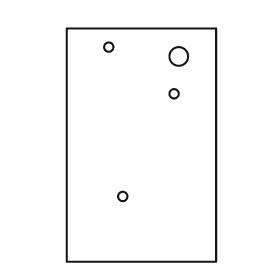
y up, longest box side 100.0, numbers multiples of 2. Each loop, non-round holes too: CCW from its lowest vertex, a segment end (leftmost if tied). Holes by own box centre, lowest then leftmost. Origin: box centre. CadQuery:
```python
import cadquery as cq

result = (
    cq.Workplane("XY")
    .moveTo(-32.0, -50.0)
    .lineTo(32.0, -50.0)
    .lineTo(32.0, 50.0)
    .lineTo(-32.0, 50.0)
    .close()
    .moveTo(-8.0, -22.0)
    .circle(2.0)
    .moveTo(14.0, 22.0)
    .circle(2.0)
    .moveTo(16.0, 38.0)
    .circle(4.0)
    .moveTo(-14.0, 42.0)
    .circle(2.0)
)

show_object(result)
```